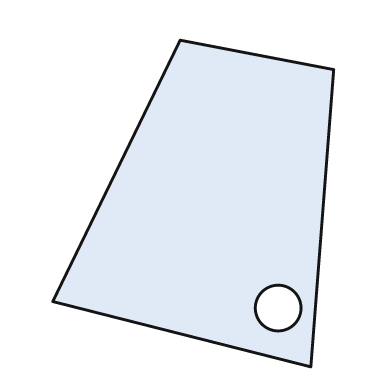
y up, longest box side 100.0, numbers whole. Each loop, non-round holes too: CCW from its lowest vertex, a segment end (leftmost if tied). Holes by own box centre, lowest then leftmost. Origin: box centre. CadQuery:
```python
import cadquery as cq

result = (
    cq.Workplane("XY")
    .moveTo(36.0, -50.0)
    .lineTo(43.0, 41.0)
    .lineTo(-4.0, 50.0)
    .lineTo(-43.0, -30.0)
    .close()
    .moveTo(26.0, -32.0)
    .circle(7.0)
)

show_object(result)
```